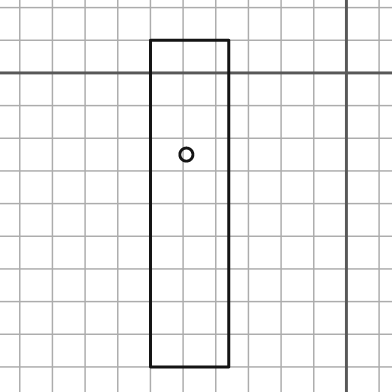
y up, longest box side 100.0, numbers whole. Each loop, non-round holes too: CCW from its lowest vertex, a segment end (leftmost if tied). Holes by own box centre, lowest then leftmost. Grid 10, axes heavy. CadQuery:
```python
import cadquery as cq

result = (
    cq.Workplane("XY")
    .moveTo(-60.0, -90.0)
    .lineTo(-36.0, -90.0)
    .lineTo(-36.0, 10.0)
    .lineTo(-60.0, 10.0)
    .close()
    .moveTo(-49.0, -25.0)
    .circle(2.0)
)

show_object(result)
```